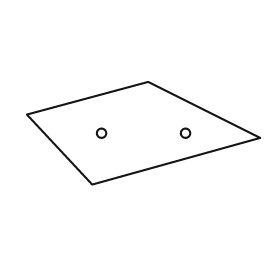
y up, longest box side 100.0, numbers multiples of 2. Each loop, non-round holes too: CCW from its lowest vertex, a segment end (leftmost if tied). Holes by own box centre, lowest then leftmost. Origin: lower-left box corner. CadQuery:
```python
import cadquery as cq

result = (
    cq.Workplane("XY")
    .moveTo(28.0, 0.0)
    .lineTo(100.0, 20.0)
    .lineTo(52.0, 44.0)
    .lineTo(0.0, 30.0)
    .close()
    .moveTo(32.0, 22.0)
    .circle(2.0)
    .moveTo(68.0, 22.0)
    .circle(2.0)
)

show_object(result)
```